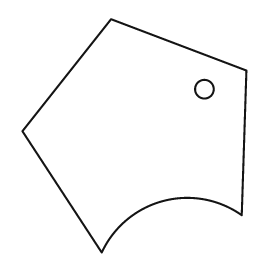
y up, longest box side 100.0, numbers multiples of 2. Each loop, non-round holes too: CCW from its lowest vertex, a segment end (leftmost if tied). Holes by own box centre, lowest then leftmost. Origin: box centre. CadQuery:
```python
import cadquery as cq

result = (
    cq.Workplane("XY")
    .moveTo(-14.0, -50.0)
    .threePointArc((12.0, -28.0), (46.0, -34.0))
    .lineTo(48.0, 28.0)
    .lineTo(-10.0, 50.0)
    .lineTo(-48.0, 2.0)
    .close()
    .moveTo(30.0, 20.0)
    .circle(4.0)
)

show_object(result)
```